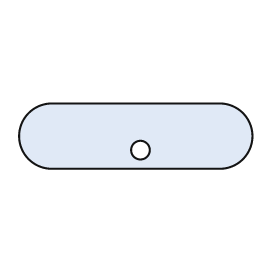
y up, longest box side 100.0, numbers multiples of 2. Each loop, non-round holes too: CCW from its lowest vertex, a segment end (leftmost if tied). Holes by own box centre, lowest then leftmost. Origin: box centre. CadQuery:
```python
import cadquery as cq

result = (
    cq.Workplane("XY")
    .moveTo(-36.0, -14.0)
    .lineTo(36.0, -14.0)
    .threePointArc((50.0, 0.0), (36.0, 14.0))
    .lineTo(-36.0, 14.0)
    .threePointArc((-50.0, 0.0), (-36.0, -14.0))
    .close()
    .moveTo(2.0, -6.0)
    .circle(4.0)
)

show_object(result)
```